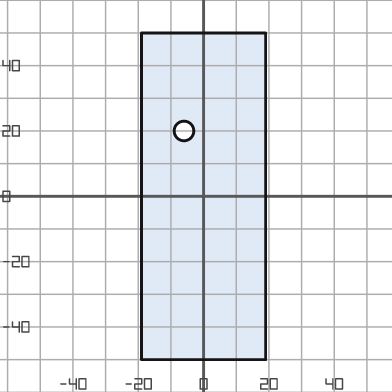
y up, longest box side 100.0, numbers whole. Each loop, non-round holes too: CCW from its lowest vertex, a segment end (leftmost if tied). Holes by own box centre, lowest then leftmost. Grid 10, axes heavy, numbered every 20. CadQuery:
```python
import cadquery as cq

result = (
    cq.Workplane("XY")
    .moveTo(-19.0, -50.0)
    .lineTo(19.0, -50.0)
    .lineTo(19.0, 50.0)
    .lineTo(-19.0, 50.0)
    .close()
    .moveTo(-6.0, 20.0)
    .circle(3.0)
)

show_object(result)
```